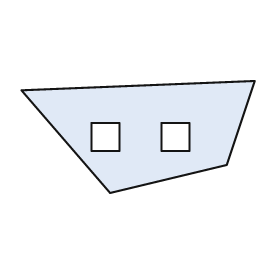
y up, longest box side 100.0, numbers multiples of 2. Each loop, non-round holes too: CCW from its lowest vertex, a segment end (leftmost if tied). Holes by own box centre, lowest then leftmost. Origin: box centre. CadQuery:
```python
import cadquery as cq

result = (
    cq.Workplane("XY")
    .moveTo(-12.0, -24.0)
    .lineTo(38.0, -12.0)
    .lineTo(50.0, 24.0)
    .lineTo(-50.0, 20.0)
    .close()
    .moveTo(-20.0, -6.0)
    .lineTo(-8.0, -6.0)
    .lineTo(-8.0, 6.0)
    .lineTo(-20.0, 6.0)
    .close()
    .moveTo(10.0, -6.0)
    .lineTo(22.0, -6.0)
    .lineTo(22.0, 6.0)
    .lineTo(10.0, 6.0)
    .close()
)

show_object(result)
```